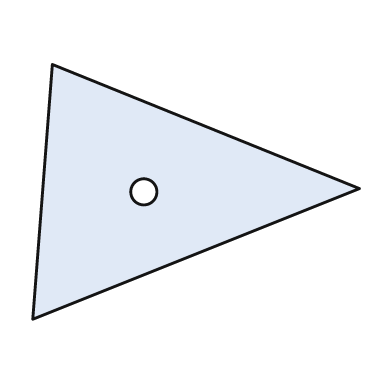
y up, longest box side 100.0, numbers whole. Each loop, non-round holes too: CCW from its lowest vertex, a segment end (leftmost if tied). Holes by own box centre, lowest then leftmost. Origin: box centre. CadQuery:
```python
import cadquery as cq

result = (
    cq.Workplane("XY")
    .moveTo(-50.0, -39.0)
    .lineTo(50.0, 1.0)
    .lineTo(-44.0, 39.0)
    .close()
    .moveTo(-16.0, 0.0)
    .circle(4.0)
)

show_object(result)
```